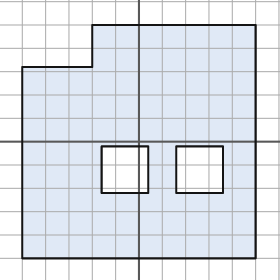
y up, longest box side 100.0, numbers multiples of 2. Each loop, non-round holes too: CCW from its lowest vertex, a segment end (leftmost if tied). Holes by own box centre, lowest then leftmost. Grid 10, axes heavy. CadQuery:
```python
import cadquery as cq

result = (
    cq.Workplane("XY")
    .moveTo(-50.0, -50.0)
    .lineTo(50.0, -50.0)
    .lineTo(50.0, 50.0)
    .lineTo(-20.0, 50.0)
    .lineTo(-20.0, 32.0)
    .lineTo(-50.0, 32.0)
    .close()
    .moveTo(-16.0, -22.0)
    .lineTo(4.0, -22.0)
    .lineTo(4.0, -2.0)
    .lineTo(-16.0, -2.0)
    .close()
    .moveTo(16.0, -22.0)
    .lineTo(36.0, -22.0)
    .lineTo(36.0, -2.0)
    .lineTo(16.0, -2.0)
    .close()
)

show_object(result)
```